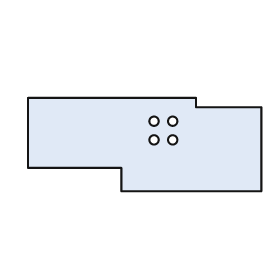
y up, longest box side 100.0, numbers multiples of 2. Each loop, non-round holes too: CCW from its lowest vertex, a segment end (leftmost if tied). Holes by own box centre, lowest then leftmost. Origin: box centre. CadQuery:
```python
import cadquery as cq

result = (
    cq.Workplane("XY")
    .moveTo(-10.0, -20.0)
    .lineTo(50.0, -20.0)
    .lineTo(50.0, 16.0)
    .lineTo(22.0, 16.0)
    .lineTo(22.0, 20.0)
    .lineTo(-50.0, 20.0)
    .lineTo(-50.0, -10.0)
    .lineTo(-10.0, -10.0)
    .close()
    .moveTo(4.0, 2.0)
    .circle(2.0)
    .moveTo(12.0, 2.0)
    .circle(2.0)
    .moveTo(4.0, 10.0)
    .circle(2.0)
    .moveTo(12.0, 10.0)
    .circle(2.0)
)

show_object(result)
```